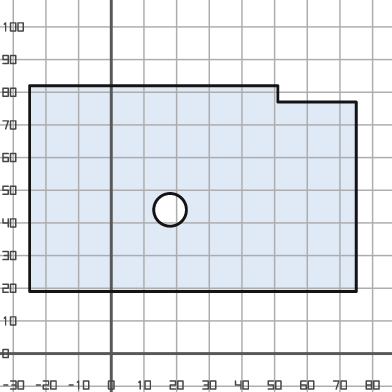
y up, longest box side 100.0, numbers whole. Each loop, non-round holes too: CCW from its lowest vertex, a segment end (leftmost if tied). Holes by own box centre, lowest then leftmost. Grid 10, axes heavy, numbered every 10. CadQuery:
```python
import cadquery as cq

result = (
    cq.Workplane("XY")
    .moveTo(-25.0, 19.0)
    .lineTo(75.0, 19.0)
    .lineTo(75.0, 77.0)
    .lineTo(51.0, 77.0)
    .lineTo(51.0, 82.0)
    .lineTo(-25.0, 82.0)
    .close()
    .moveTo(18.0, 44.0)
    .circle(5.0)
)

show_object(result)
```